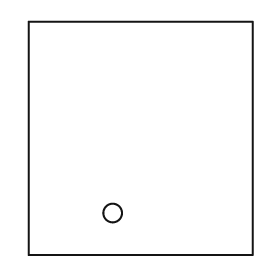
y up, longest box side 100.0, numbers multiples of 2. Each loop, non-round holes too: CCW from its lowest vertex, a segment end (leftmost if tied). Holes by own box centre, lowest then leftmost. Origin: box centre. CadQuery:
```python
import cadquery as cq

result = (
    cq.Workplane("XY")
    .moveTo(-48.0, -50.0)
    .lineTo(48.0, -50.0)
    .lineTo(48.0, 50.0)
    .lineTo(-48.0, 50.0)
    .close()
    .moveTo(-12.0, -32.0)
    .circle(4.0)
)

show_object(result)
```